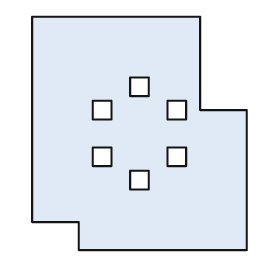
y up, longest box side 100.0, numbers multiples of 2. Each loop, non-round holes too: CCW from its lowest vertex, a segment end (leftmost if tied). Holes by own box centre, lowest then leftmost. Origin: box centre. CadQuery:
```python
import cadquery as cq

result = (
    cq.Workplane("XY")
    .moveTo(-26.0, -50.0)
    .lineTo(46.0, -50.0)
    .lineTo(46.0, 10.0)
    .lineTo(26.0, 10.0)
    .lineTo(26.0, 50.0)
    .lineTo(-46.0, 50.0)
    .lineTo(-46.0, -38.0)
    .lineTo(-26.0, -38.0)
    .close()
    .moveTo(-4.0, -24.0)
    .lineTo(4.0, -24.0)
    .lineTo(4.0, -16.0)
    .lineTo(-4.0, -16.0)
    .close()
    .moveTo(-20.0, -14.0)
    .lineTo(-12.0, -14.0)
    .lineTo(-12.0, -6.0)
    .lineTo(-20.0, -6.0)
    .close()
    .moveTo(12.0, -14.0)
    .lineTo(20.0, -14.0)
    .lineTo(20.0, -6.0)
    .lineTo(12.0, -6.0)
    .close()
    .moveTo(-20.0, 6.0)
    .lineTo(-12.0, 6.0)
    .lineTo(-12.0, 14.0)
    .lineTo(-20.0, 14.0)
    .close()
    .moveTo(12.0, 6.0)
    .lineTo(20.0, 6.0)
    .lineTo(20.0, 14.0)
    .lineTo(12.0, 14.0)
    .close()
    .moveTo(-4.0, 16.0)
    .lineTo(4.0, 16.0)
    .lineTo(4.0, 24.0)
    .lineTo(-4.0, 24.0)
    .close()
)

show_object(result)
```